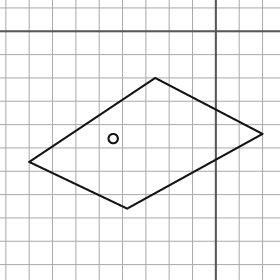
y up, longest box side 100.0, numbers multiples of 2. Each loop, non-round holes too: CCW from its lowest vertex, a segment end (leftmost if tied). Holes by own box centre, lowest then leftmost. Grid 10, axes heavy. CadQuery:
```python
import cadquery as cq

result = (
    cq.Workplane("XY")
    .moveTo(-38.0, -76.0)
    .lineTo(20.0, -44.0)
    .lineTo(-26.0, -20.0)
    .lineTo(-80.0, -56.0)
    .close()
    .moveTo(-44.0, -46.0)
    .circle(2.0)
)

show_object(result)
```